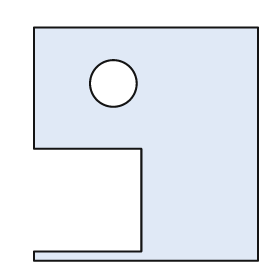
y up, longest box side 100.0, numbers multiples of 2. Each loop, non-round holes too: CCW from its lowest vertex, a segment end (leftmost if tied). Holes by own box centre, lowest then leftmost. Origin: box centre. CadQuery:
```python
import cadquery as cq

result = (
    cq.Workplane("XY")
    .moveTo(-48.0, -50.0)
    .lineTo(48.0, -50.0)
    .lineTo(48.0, 50.0)
    .lineTo(-48.0, 50.0)
    .lineTo(-48.0, -2.0)
    .lineTo(-2.0, -2.0)
    .lineTo(-2.0, -46.0)
    .lineTo(-48.0, -46.0)
    .close()
    .moveTo(-14.0, 26.0)
    .circle(10.0)
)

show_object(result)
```